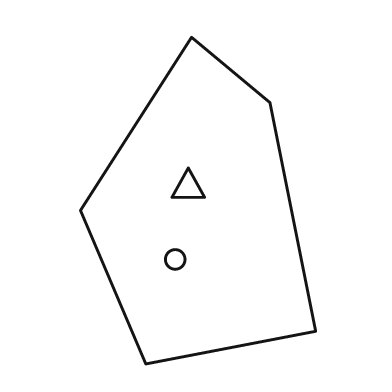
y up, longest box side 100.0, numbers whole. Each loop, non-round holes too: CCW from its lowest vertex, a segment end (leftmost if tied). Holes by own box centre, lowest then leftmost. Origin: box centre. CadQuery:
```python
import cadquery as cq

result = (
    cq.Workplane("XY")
    .moveTo(-16.0, -50.0)
    .lineTo(36.0, -40.0)
    .lineTo(22.0, 30.0)
    .lineTo(-2.0, 50.0)
    .lineTo(-36.0, -3.0)
    .close()
    .moveTo(-7.0, -18.0)
    .circle(3.0)
    .moveTo(-8.0, 1.0)
    .lineTo(2.0, 1.0)
    .lineTo(-3.0, 10.0)
    .close()
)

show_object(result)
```